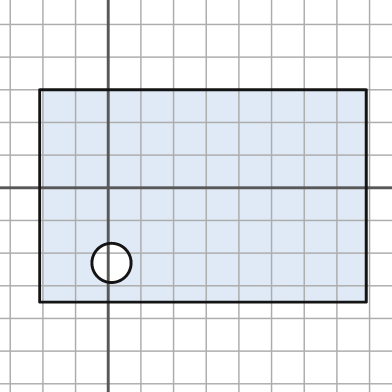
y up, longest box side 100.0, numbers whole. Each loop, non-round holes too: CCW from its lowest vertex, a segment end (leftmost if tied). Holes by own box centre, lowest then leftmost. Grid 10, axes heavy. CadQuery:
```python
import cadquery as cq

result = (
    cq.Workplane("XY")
    .moveTo(-21.0, -35.0)
    .lineTo(79.0, -35.0)
    .lineTo(79.0, 30.0)
    .lineTo(-21.0, 30.0)
    .close()
    .moveTo(1.0, -23.0)
    .circle(6.0)
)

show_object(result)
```